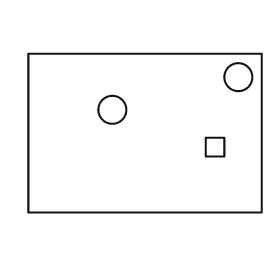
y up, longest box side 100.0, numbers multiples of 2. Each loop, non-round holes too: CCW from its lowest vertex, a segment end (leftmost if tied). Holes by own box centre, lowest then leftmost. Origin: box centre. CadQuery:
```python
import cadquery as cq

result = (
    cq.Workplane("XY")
    .moveTo(-50.0, -34.0)
    .lineTo(50.0, -34.0)
    .lineTo(50.0, 34.0)
    .lineTo(-50.0, 34.0)
    .close()
    .moveTo(26.0, -10.0)
    .lineTo(34.0, -10.0)
    .lineTo(34.0, -2.0)
    .lineTo(26.0, -2.0)
    .close()
    .moveTo(-14.0, 10.0)
    .circle(6.0)
    .moveTo(40.0, 24.0)
    .circle(6.0)
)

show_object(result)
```